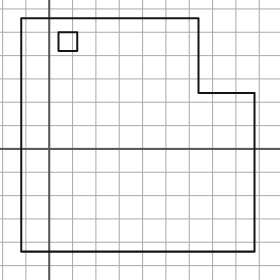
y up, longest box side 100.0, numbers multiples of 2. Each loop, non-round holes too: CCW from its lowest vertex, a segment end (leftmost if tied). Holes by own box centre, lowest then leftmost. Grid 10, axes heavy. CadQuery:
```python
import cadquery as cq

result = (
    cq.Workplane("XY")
    .moveTo(-12.0, -44.0)
    .lineTo(88.0, -44.0)
    .lineTo(88.0, 24.0)
    .lineTo(64.0, 24.0)
    .lineTo(64.0, 56.0)
    .lineTo(-12.0, 56.0)
    .close()
    .moveTo(4.0, 42.0)
    .lineTo(12.0, 42.0)
    .lineTo(12.0, 50.0)
    .lineTo(4.0, 50.0)
    .close()
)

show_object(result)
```